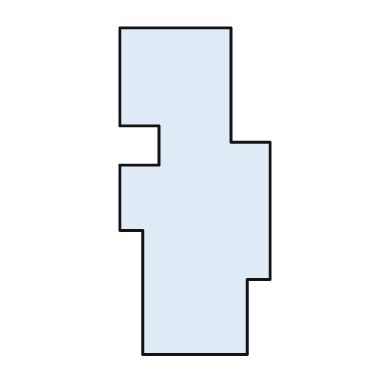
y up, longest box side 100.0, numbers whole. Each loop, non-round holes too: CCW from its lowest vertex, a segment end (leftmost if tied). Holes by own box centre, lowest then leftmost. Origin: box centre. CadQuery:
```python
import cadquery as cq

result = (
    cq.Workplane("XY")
    .moveTo(-16.0, -50.0)
    .lineTo(16.0, -50.0)
    .lineTo(16.0, -27.0)
    .lineTo(23.0, -27.0)
    .lineTo(23.0, 15.0)
    .lineTo(11.0, 15.0)
    .lineTo(11.0, 50.0)
    .lineTo(-23.0, 50.0)
    .lineTo(-23.0, 20.0)
    .lineTo(-11.0, 20.0)
    .lineTo(-11.0, 8.0)
    .lineTo(-23.0, 8.0)
    .lineTo(-23.0, -12.0)
    .lineTo(-16.0, -12.0)
    .close()
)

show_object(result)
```